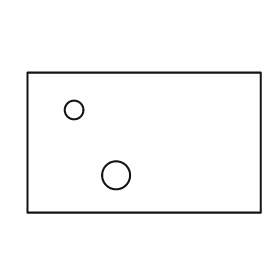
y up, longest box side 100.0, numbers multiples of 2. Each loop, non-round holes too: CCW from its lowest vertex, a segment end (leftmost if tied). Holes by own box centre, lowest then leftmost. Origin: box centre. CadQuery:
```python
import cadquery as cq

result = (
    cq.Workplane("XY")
    .moveTo(-50.0, -30.0)
    .lineTo(50.0, -30.0)
    .lineTo(50.0, 30.0)
    .lineTo(-50.0, 30.0)
    .close()
    .moveTo(-12.0, -14.0)
    .circle(6.0)
    .moveTo(-30.0, 14.0)
    .circle(4.0)
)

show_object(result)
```